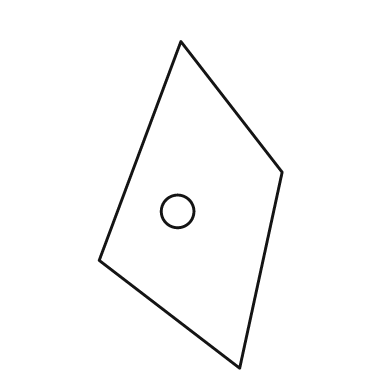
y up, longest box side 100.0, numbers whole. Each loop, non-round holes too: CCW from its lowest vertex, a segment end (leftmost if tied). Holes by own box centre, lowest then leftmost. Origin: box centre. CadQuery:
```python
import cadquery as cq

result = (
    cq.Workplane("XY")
    .moveTo(15.0, -50.0)
    .lineTo(28.0, 10.0)
    .lineTo(-3.0, 50.0)
    .lineTo(-28.0, -17.0)
    .close()
    .moveTo(-4.0, -2.0)
    .circle(5.0)
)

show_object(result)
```